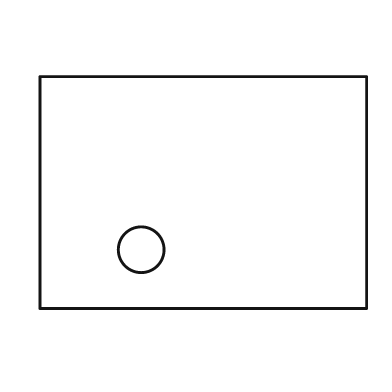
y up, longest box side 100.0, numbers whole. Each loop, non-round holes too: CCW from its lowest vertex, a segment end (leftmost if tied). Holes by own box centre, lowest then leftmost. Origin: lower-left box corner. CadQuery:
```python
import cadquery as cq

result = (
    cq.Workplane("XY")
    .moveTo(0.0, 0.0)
    .lineTo(100.0, 0.0)
    .lineTo(100.0, 71.0)
    .lineTo(0.0, 71.0)
    .close()
    .moveTo(31.0, 18.0)
    .circle(7.0)
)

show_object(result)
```